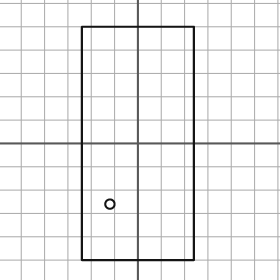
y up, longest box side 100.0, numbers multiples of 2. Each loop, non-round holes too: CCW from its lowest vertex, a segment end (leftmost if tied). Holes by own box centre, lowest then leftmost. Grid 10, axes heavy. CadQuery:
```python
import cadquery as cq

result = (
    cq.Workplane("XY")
    .moveTo(-24.0, -50.0)
    .lineTo(24.0, -50.0)
    .lineTo(24.0, 50.0)
    .lineTo(-24.0, 50.0)
    .close()
    .moveTo(-12.0, -26.0)
    .circle(2.0)
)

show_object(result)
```